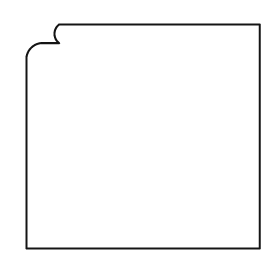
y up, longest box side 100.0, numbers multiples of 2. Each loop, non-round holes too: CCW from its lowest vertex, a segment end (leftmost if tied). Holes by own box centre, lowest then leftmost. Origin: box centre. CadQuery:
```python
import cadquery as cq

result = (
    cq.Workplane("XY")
    .moveTo(-50.0, -48.0)
    .lineTo(50.0, -48.0)
    .lineTo(50.0, 48.0)
    .lineTo(-36.0, 48.0)
    .threePointArc((-38.0, 44.0), (-36.0, 40.0))
    .lineTo(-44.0, 40.0)
    .threePointArc((-48.0, 38.0), (-50.0, 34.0))
    .close()
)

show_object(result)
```